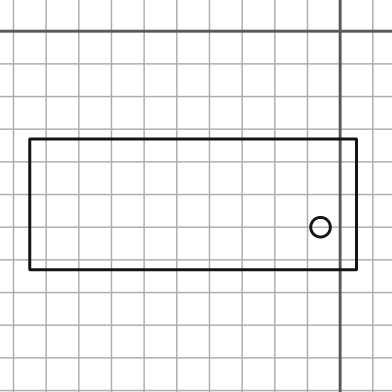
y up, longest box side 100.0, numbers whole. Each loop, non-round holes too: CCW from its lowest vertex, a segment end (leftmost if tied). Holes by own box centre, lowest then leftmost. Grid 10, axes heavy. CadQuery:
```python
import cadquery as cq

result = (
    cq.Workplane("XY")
    .moveTo(-95.0, -73.0)
    .lineTo(5.0, -73.0)
    .lineTo(5.0, -33.0)
    .lineTo(-95.0, -33.0)
    .close()
    .moveTo(-6.0, -60.0)
    .circle(3.0)
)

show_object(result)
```